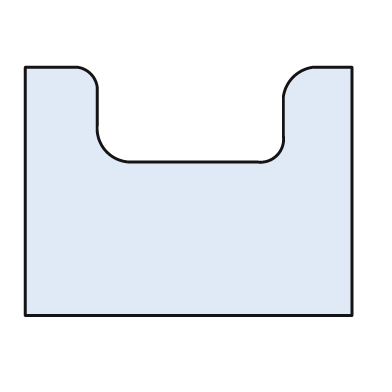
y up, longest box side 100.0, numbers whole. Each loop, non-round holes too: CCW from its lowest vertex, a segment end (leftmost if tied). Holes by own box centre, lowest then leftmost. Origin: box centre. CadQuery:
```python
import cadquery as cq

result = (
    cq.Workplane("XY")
    .moveTo(-50.0, -38.0)
    .lineTo(50.0, -38.0)
    .lineTo(50.0, 38.0)
    .lineTo(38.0, 38.0)
    .threePointArc((32.0, 35.0), (29.0, 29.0))
    .lineTo(29.0, 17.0)
    .threePointArc((27.0, 11.0), (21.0, 9.0))
    .lineTo(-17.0, 9.0)
    .threePointArc((-25.0, 12.0), (-28.0, 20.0))
    .lineTo(-28.0, 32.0)
    .threePointArc((-30.0, 36.0), (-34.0, 38.0))
    .lineTo(-50.0, 38.0)
    .close()
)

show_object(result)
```